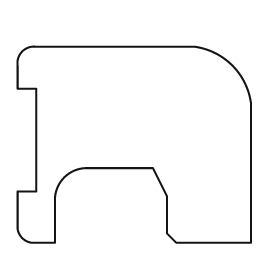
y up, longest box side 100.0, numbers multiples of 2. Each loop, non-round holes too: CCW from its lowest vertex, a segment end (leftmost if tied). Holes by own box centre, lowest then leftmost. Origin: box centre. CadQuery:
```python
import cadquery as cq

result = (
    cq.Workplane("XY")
    .moveTo(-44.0, -42.0)
    .lineTo(-34.0, -42.0)
    .lineTo(-34.0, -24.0)
    .threePointArc((-30.0, -14.0), (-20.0, -10.0))
    .lineTo(8.0, -10.0)
    .lineTo(14.0, -22.0)
    .lineTo(14.0, -38.0)
    .lineTo(18.0, -42.0)
    .lineTo(50.0, -42.0)
    .lineTo(50.0, 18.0)
    .threePointArc((42.0, 34.0), (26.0, 42.0))
    .lineTo(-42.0, 42.0)
    .threePointArc((-48.0, 40.0), (-50.0, 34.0))
    .lineTo(-50.0, 24.0)
    .lineTo(-42.0, 24.0)
    .lineTo(-42.0, -20.0)
    .lineTo(-50.0, -20.0)
    .lineTo(-50.0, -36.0)
    .threePointArc((-48.0, -40.0), (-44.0, -42.0))
    .close()
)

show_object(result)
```